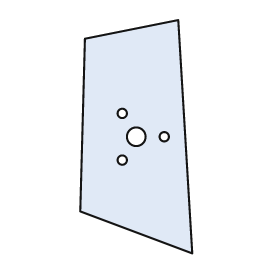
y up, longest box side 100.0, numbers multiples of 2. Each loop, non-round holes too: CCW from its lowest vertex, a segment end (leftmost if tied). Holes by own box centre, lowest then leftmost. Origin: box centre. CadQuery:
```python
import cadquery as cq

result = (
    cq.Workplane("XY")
    .moveTo(24.0, -50.0)
    .lineTo(18.0, 50.0)
    .lineTo(-22.0, 42.0)
    .lineTo(-24.0, -32.0)
    .close()
    .moveTo(-6.0, -10.0)
    .circle(2.0)
    .moveTo(0.0, 0.0)
    .circle(4.0)
    .moveTo(12.0, 0.0)
    .circle(2.0)
    .moveTo(-6.0, 10.0)
    .circle(2.0)
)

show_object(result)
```